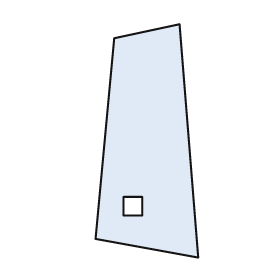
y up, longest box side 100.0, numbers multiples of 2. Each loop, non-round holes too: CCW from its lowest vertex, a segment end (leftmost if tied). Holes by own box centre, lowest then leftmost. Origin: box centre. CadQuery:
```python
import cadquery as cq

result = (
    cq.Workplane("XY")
    .moveTo(22.0, -50.0)
    .lineTo(14.0, 50.0)
    .lineTo(-14.0, 44.0)
    .lineTo(-22.0, -42.0)
    .close()
    .moveTo(-10.0, -32.0)
    .lineTo(-2.0, -32.0)
    .lineTo(-2.0, -24.0)
    .lineTo(-10.0, -24.0)
    .close()
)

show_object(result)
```